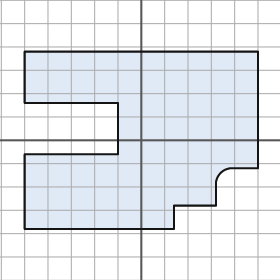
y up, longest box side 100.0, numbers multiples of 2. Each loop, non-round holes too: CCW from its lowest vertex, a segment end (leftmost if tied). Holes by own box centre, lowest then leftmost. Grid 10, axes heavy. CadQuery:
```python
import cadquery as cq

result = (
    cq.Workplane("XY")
    .moveTo(-50.0, -38.0)
    .lineTo(14.0, -38.0)
    .lineTo(14.0, -28.0)
    .lineTo(32.0, -28.0)
    .lineTo(32.0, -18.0)
    .threePointArc((34.0, -14.0), (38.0, -12.0))
    .lineTo(50.0, -12.0)
    .lineTo(50.0, 38.0)
    .lineTo(-50.0, 38.0)
    .lineTo(-50.0, 16.0)
    .lineTo(-10.0, 16.0)
    .lineTo(-10.0, -6.0)
    .lineTo(-50.0, -6.0)
    .close()
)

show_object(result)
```